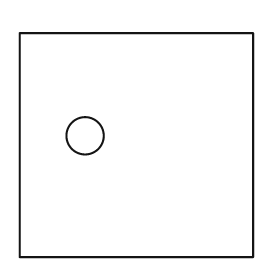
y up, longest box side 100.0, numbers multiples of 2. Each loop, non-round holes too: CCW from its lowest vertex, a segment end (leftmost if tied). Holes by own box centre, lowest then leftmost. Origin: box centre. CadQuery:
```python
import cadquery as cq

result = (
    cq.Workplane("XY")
    .moveTo(-50.0, -48.0)
    .lineTo(50.0, -48.0)
    .lineTo(50.0, 48.0)
    .lineTo(-50.0, 48.0)
    .close()
    .moveTo(-22.0, 4.0)
    .circle(8.0)
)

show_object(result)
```